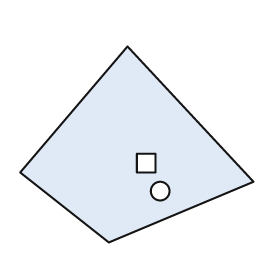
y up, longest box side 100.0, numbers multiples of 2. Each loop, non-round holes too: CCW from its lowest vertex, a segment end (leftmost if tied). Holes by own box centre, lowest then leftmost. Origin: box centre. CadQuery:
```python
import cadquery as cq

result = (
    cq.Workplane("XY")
    .moveTo(-12.0, -42.0)
    .lineTo(50.0, -16.0)
    .lineTo(-4.0, 42.0)
    .lineTo(-50.0, -12.0)
    .close()
    .moveTo(10.0, -20.0)
    .circle(4.0)
    .moveTo(0.0, -12.0)
    .lineTo(8.0, -12.0)
    .lineTo(8.0, -4.0)
    .lineTo(0.0, -4.0)
    .close()
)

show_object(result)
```